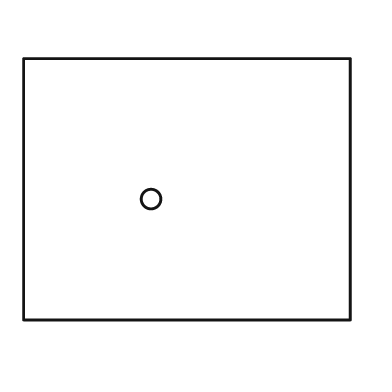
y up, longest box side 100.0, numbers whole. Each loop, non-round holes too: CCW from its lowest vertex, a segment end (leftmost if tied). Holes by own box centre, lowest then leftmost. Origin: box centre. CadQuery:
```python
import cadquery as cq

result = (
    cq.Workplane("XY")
    .moveTo(-50.0, -40.0)
    .lineTo(50.0, -40.0)
    .lineTo(50.0, 40.0)
    .lineTo(-50.0, 40.0)
    .close()
    .moveTo(-11.0, -3.0)
    .circle(3.0)
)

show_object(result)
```